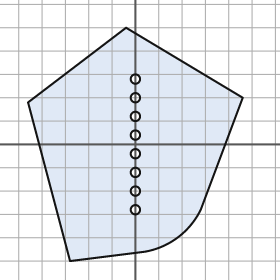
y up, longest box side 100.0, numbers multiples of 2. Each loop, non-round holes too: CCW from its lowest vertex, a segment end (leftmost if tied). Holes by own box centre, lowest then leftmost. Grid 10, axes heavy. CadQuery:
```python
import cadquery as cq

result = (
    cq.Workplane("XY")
    .moveTo(-28.0, -50.0)
    .lineTo(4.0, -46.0)
    .threePointArc((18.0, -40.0), (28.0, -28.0))
    .lineTo(46.0, 20.0)
    .lineTo(-4.0, 50.0)
    .lineTo(-46.0, 18.0)
    .close()
    .moveTo(0.0, -28.0)
    .circle(2.0)
    .moveTo(0.0, -20.0)
    .circle(2.0)
    .moveTo(0.0, -12.0)
    .circle(2.0)
    .moveTo(0.0, -4.0)
    .circle(2.0)
    .moveTo(0.0, 4.0)
    .circle(2.0)
    .moveTo(0.0, 12.0)
    .circle(2.0)
    .moveTo(0.0, 20.0)
    .circle(2.0)
    .moveTo(0.0, 28.0)
    .circle(2.0)
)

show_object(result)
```